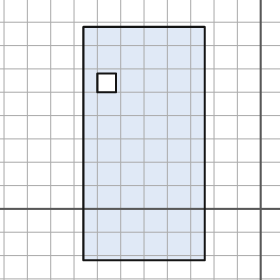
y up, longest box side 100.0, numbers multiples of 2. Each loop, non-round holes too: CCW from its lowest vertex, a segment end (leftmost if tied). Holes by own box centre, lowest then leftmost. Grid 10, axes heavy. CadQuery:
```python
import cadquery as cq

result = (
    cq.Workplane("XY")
    .moveTo(-76.0, -22.0)
    .lineTo(-24.0, -22.0)
    .lineTo(-24.0, 78.0)
    .lineTo(-76.0, 78.0)
    .close()
    .moveTo(-70.0, 50.0)
    .lineTo(-62.0, 50.0)
    .lineTo(-62.0, 58.0)
    .lineTo(-70.0, 58.0)
    .close()
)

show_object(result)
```